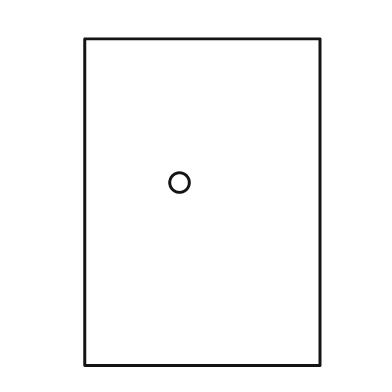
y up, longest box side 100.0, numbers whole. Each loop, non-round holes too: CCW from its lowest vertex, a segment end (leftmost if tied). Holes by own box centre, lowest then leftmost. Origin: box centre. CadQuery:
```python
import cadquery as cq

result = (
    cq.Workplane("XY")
    .moveTo(-36.0, -50.0)
    .lineTo(36.0, -50.0)
    .lineTo(36.0, 50.0)
    .lineTo(-36.0, 50.0)
    .close()
    .moveTo(-7.0, 6.0)
    .circle(3.0)
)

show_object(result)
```